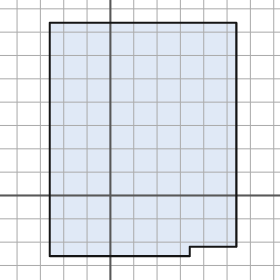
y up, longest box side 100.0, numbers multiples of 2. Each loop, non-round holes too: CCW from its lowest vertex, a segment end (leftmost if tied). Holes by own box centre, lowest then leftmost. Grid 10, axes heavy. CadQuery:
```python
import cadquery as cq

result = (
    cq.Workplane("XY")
    .moveTo(-26.0, -26.0)
    .lineTo(34.0, -26.0)
    .lineTo(34.0, -22.0)
    .lineTo(54.0, -22.0)
    .lineTo(54.0, 74.0)
    .lineTo(-26.0, 74.0)
    .close()
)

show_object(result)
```